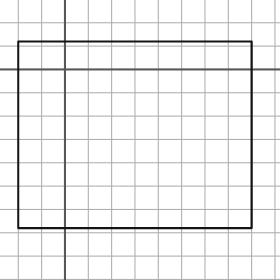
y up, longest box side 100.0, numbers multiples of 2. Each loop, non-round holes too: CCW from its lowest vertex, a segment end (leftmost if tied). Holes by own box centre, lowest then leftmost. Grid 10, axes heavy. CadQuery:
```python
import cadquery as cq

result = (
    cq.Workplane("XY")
    .moveTo(-20.0, -68.0)
    .lineTo(80.0, -68.0)
    .lineTo(80.0, 12.0)
    .lineTo(-20.0, 12.0)
    .close()
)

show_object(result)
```